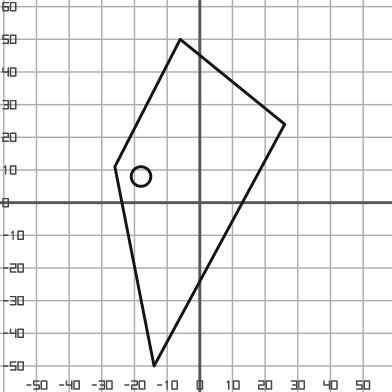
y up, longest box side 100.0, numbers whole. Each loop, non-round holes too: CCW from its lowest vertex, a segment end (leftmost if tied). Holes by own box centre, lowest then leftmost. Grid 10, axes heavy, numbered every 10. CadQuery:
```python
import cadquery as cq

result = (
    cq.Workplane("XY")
    .moveTo(-14.0, -50.0)
    .lineTo(26.0, 24.0)
    .lineTo(-6.0, 50.0)
    .lineTo(-26.0, 11.0)
    .close()
    .moveTo(-18.0, 8.0)
    .circle(3.0)
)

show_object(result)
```